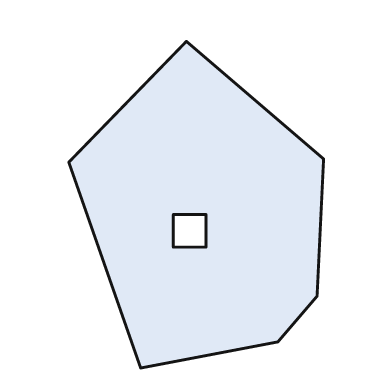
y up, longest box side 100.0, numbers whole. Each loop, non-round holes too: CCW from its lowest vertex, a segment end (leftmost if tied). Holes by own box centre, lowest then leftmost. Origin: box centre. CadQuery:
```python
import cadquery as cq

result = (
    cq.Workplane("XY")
    .moveTo(-17.0, -50.0)
    .lineTo(25.0, -42.0)
    .lineTo(37.0, -28.0)
    .lineTo(39.0, 14.0)
    .lineTo(-3.0, 50.0)
    .lineTo(-39.0, 13.0)
    .close()
    .moveTo(-7.0, -13.0)
    .lineTo(3.0, -13.0)
    .lineTo(3.0, -3.0)
    .lineTo(-7.0, -3.0)
    .close()
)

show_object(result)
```